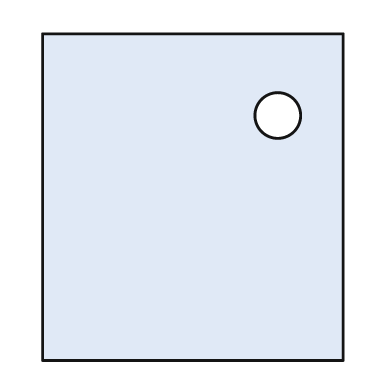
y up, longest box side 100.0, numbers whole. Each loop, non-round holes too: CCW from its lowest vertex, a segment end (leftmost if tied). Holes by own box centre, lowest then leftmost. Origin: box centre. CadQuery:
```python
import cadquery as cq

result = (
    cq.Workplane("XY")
    .moveTo(-46.0, -50.0)
    .lineTo(46.0, -50.0)
    .lineTo(46.0, 50.0)
    .lineTo(-46.0, 50.0)
    .close()
    .moveTo(26.0, 25.0)
    .circle(7.0)
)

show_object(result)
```